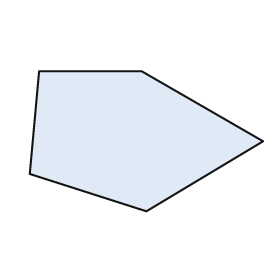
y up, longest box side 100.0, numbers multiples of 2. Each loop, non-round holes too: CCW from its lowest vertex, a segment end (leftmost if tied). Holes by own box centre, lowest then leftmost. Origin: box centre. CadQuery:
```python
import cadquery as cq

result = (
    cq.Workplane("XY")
    .moveTo(0.0, -30.0)
    .lineTo(50.0, 0.0)
    .lineTo(-2.0, 30.0)
    .lineTo(-46.0, 30.0)
    .lineTo(-50.0, -14.0)
    .close()
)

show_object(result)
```